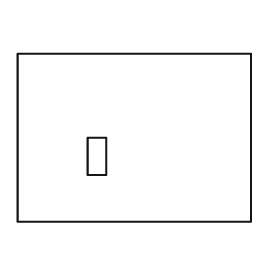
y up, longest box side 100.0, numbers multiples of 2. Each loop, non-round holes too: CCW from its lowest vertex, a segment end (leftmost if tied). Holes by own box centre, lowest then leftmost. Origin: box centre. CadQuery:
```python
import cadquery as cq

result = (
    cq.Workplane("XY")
    .moveTo(-50.0, -36.0)
    .lineTo(50.0, -36.0)
    .lineTo(50.0, 36.0)
    .lineTo(-50.0, 36.0)
    .close()
    .moveTo(-20.0, -16.0)
    .lineTo(-12.0, -16.0)
    .lineTo(-12.0, 0.0)
    .lineTo(-20.0, 0.0)
    .close()
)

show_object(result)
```